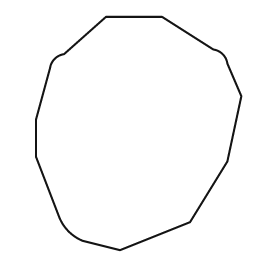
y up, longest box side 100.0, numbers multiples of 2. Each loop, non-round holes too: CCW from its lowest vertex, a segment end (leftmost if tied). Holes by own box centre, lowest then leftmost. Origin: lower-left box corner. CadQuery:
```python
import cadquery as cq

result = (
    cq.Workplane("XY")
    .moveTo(36.0, 0.0)
    .lineTo(66.0, 12.0)
    .lineTo(82.0, 38.0)
    .lineTo(88.0, 66.0)
    .lineTo(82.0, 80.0)
    .threePointArc((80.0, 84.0), (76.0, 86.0))
    .lineTo(54.0, 100.0)
    .lineTo(30.0, 100.0)
    .lineTo(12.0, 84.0)
    .threePointArc((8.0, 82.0), (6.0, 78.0))
    .lineTo(0.0, 56.0)
    .lineTo(0.0, 40.0)
    .lineTo(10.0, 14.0)
    .threePointArc((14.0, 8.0), (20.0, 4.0))
    .close()
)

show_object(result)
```